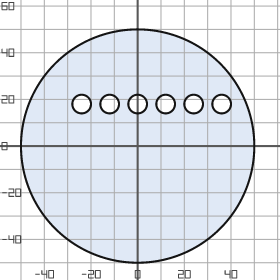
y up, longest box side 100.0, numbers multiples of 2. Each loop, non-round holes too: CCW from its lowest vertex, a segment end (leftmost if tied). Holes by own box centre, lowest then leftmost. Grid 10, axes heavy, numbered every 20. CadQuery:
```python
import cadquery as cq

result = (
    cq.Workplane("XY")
    .moveTo(0.0, 0.0)
    .circle(50.0)
    .moveTo(-24.0, 18.0)
    .circle(4.0)
    .moveTo(-12.0, 18.0)
    .circle(4.0)
    .moveTo(0.0, 18.0)
    .circle(4.0)
    .moveTo(12.0, 18.0)
    .circle(4.0)
    .moveTo(24.0, 18.0)
    .circle(4.0)
    .moveTo(36.0, 18.0)
    .circle(4.0)
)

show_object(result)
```